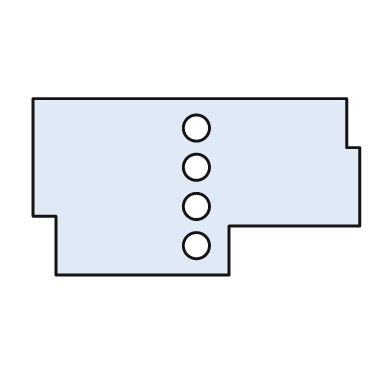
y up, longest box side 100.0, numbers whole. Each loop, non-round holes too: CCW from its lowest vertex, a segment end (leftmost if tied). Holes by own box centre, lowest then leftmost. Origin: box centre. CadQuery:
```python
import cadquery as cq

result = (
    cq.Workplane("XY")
    .moveTo(-43.0, -27.0)
    .lineTo(10.0, -27.0)
    .lineTo(10.0, -12.0)
    .lineTo(50.0, -12.0)
    .lineTo(50.0, 12.0)
    .lineTo(46.0, 12.0)
    .lineTo(46.0, 27.0)
    .lineTo(-50.0, 27.0)
    .lineTo(-50.0, -9.0)
    .lineTo(-43.0, -9.0)
    .close()
    .moveTo(0.0, -18.0)
    .circle(4.0)
    .moveTo(0.0, -6.0)
    .circle(4.0)
    .moveTo(0.0, 6.0)
    .circle(4.0)
    .moveTo(0.0, 18.0)
    .circle(4.0)
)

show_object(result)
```